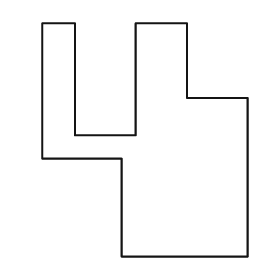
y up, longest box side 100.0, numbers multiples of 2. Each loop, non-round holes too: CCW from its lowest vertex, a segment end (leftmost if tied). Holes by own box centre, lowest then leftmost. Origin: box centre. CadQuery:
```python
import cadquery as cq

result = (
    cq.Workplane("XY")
    .moveTo(-10.0, -50.0)
    .lineTo(44.0, -50.0)
    .lineTo(44.0, 18.0)
    .lineTo(18.0, 18.0)
    .lineTo(18.0, 50.0)
    .lineTo(-4.0, 50.0)
    .lineTo(-4.0, 2.0)
    .lineTo(-30.0, 2.0)
    .lineTo(-30.0, 50.0)
    .lineTo(-44.0, 50.0)
    .lineTo(-44.0, -8.0)
    .lineTo(-10.0, -8.0)
    .close()
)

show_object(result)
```